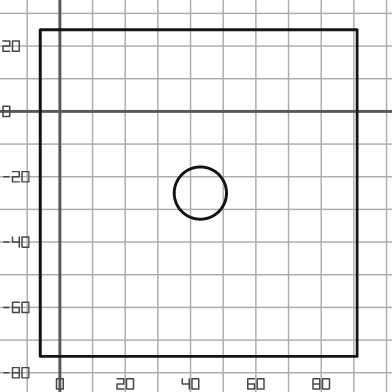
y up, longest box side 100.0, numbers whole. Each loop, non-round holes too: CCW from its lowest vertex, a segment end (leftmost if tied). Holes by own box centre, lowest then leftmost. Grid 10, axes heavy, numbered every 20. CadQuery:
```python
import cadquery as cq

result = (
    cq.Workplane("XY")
    .moveTo(-6.0, -75.0)
    .lineTo(91.0, -75.0)
    .lineTo(91.0, 25.0)
    .lineTo(-6.0, 25.0)
    .close()
    .moveTo(43.0, -25.0)
    .circle(8.0)
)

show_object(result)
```